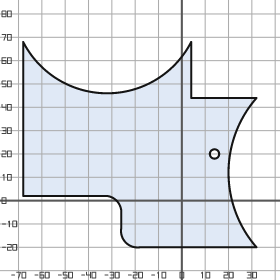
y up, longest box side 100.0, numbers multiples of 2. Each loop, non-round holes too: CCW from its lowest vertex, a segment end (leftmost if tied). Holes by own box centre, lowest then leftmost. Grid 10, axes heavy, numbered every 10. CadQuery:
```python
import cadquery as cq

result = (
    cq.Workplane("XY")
    .moveTo(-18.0, -20.0)
    .lineTo(32.0, -20.0)
    .threePointArc((20.0, 12.0), (32.0, 44.0))
    .lineTo(4.0, 44.0)
    .lineTo(4.0, 68.0)
    .threePointArc((-32.0, 46.0), (-68.0, 68.0))
    .lineTo(-68.0, 2.0)
    .lineTo(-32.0, 2.0)
    .threePointArc((-28.0, 0.0), (-26.0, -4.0))
    .lineTo(-26.0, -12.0)
    .threePointArc((-24.0, -18.0), (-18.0, -20.0))
    .close()
    .moveTo(14.0, 20.0)
    .circle(2.0)
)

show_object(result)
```